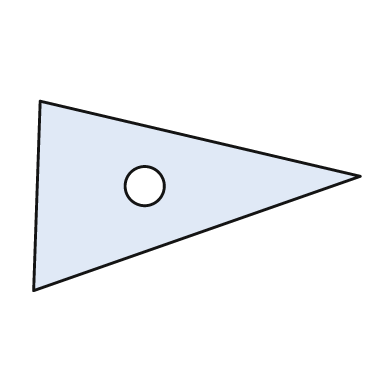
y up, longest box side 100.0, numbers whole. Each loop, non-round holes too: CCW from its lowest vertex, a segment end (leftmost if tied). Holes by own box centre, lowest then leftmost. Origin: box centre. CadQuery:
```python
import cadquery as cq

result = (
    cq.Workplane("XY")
    .moveTo(-50.0, -29.0)
    .lineTo(50.0, 6.0)
    .lineTo(-48.0, 29.0)
    .close()
    .moveTo(-16.0, 3.0)
    .circle(6.0)
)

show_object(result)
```